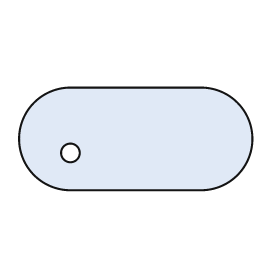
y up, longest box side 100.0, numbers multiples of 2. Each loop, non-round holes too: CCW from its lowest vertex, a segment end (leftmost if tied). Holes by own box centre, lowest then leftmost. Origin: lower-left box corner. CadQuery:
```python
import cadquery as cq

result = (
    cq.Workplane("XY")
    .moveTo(22.0, 0.0)
    .lineTo(78.0, 0.0)
    .threePointArc((100.0, 22.0), (78.0, 44.0))
    .lineTo(22.0, 44.0)
    .threePointArc((0.0, 22.0), (22.0, 0.0))
    .close()
    .moveTo(22.0, 16.0)
    .circle(4.0)
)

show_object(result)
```